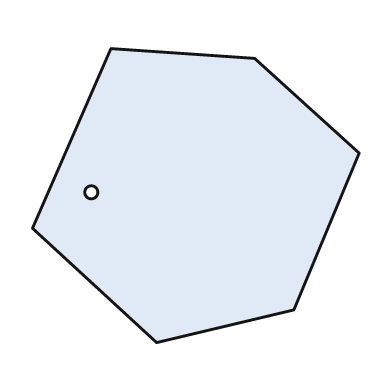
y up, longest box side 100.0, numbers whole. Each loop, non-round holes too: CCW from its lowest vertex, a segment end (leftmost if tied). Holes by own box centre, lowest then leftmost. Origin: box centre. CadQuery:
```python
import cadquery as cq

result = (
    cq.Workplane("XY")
    .moveTo(-12.0, -45.0)
    .lineTo(30.0, -35.0)
    .lineTo(50.0, 13.0)
    .lineTo(18.0, 42.0)
    .lineTo(-26.0, 45.0)
    .lineTo(-50.0, -10.0)
    .close()
    .moveTo(-32.0, 1.0)
    .circle(2.0)
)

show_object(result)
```